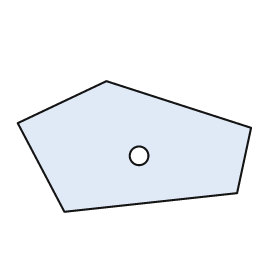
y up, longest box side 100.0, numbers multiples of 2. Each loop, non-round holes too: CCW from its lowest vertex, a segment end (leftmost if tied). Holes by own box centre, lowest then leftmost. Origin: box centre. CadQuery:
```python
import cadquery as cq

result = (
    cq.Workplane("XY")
    .moveTo(-30.0, -28.0)
    .lineTo(44.0, -20.0)
    .lineTo(50.0, 8.0)
    .lineTo(-12.0, 28.0)
    .lineTo(-50.0, 10.0)
    .close()
    .moveTo(2.0, -4.0)
    .circle(4.0)
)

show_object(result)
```